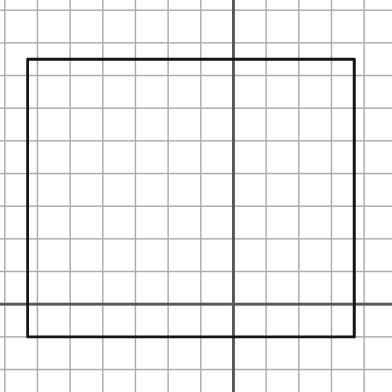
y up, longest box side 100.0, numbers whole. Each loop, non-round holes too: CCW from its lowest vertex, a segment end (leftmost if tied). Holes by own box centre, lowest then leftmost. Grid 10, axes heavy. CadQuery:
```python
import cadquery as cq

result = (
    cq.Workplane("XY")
    .moveTo(-63.0, -10.0)
    .lineTo(37.0, -10.0)
    .lineTo(37.0, 75.0)
    .lineTo(-63.0, 75.0)
    .close()
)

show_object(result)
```